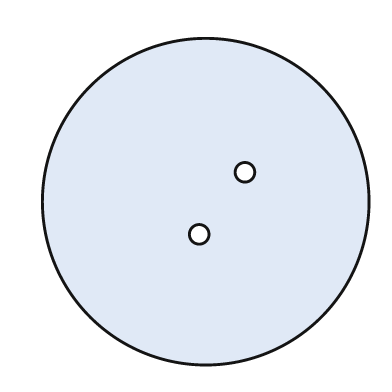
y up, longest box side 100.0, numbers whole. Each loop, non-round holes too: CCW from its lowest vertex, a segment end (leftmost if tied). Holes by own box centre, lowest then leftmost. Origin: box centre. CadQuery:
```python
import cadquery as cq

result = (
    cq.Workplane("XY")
    .moveTo(0.0, 0.0)
    .circle(50.0)
    .moveTo(-2.0, -10.0)
    .circle(3.0)
    .moveTo(12.0, 9.0)
    .circle(3.0)
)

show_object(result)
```